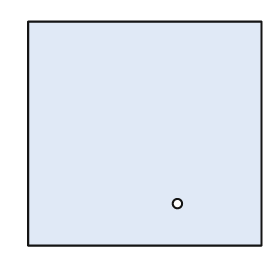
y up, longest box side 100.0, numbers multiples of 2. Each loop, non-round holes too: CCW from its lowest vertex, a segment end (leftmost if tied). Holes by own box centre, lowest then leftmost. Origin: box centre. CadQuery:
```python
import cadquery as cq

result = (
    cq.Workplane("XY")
    .moveTo(-50.0, -48.0)
    .lineTo(50.0, -48.0)
    .lineTo(50.0, 48.0)
    .lineTo(-50.0, 48.0)
    .close()
    .moveTo(14.0, -30.0)
    .circle(2.0)
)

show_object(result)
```